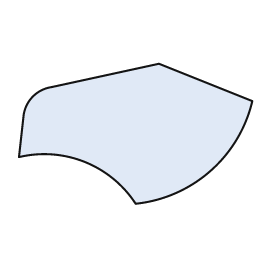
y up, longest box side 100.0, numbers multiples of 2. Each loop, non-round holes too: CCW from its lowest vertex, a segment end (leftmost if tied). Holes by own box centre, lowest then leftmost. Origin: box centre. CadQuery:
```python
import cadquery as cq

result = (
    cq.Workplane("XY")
    .moveTo(0.0, -30.0)
    .threePointArc((32.0, -16.0), (50.0, 14.0))
    .lineTo(10.0, 30.0)
    .lineTo(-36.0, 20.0)
    .threePointArc((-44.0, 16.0), (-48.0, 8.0))
    .lineTo(-50.0, -10.0)
    .threePointArc((-22.0, -12.0), (0.0, -30.0))
    .close()
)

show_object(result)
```